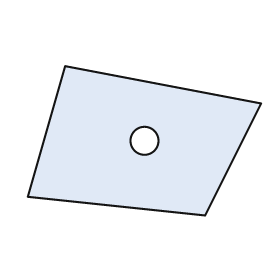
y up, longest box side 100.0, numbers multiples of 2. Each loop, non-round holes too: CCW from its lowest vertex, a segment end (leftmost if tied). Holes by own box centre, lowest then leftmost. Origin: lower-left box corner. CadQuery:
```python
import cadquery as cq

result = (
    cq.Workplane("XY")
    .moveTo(76.0, 0.0)
    .lineTo(100.0, 48.0)
    .lineTo(16.0, 64.0)
    .lineTo(0.0, 8.0)
    .close()
    .moveTo(50.0, 32.0)
    .circle(6.0)
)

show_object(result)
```